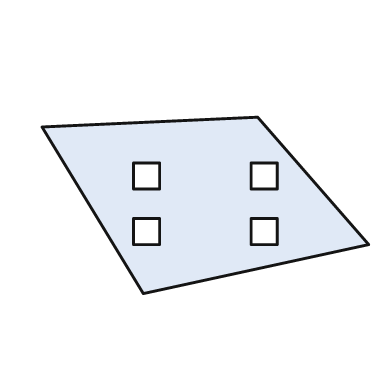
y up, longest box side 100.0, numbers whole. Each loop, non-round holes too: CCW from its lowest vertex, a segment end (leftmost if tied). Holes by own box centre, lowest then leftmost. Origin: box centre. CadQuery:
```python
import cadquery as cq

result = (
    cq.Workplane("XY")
    .moveTo(-19.0, -27.0)
    .lineTo(50.0, -12.0)
    .lineTo(16.0, 27.0)
    .lineTo(-50.0, 24.0)
    .close()
    .moveTo(-22.0, -12.0)
    .lineTo(-14.0, -12.0)
    .lineTo(-14.0, -4.0)
    .lineTo(-22.0, -4.0)
    .close()
    .moveTo(14.0, -12.0)
    .lineTo(22.0, -12.0)
    .lineTo(22.0, -4.0)
    .lineTo(14.0, -4.0)
    .close()
    .moveTo(-22.0, 5.0)
    .lineTo(-14.0, 5.0)
    .lineTo(-14.0, 13.0)
    .lineTo(-22.0, 13.0)
    .close()
    .moveTo(14.0, 5.0)
    .lineTo(22.0, 5.0)
    .lineTo(22.0, 13.0)
    .lineTo(14.0, 13.0)
    .close()
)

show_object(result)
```